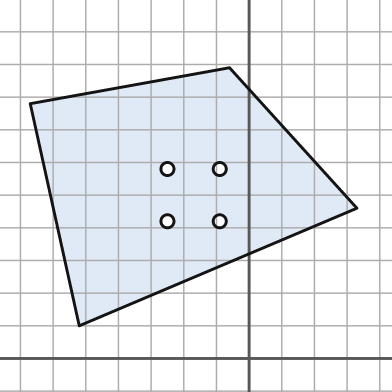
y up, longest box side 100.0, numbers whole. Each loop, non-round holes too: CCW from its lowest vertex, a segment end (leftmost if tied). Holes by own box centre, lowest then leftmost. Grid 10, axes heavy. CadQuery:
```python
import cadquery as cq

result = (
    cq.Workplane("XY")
    .moveTo(-52.0, 10.0)
    .lineTo(33.0, 46.0)
    .lineTo(-6.0, 89.0)
    .lineTo(-67.0, 78.0)
    .close()
    .moveTo(-25.0, 42.0)
    .circle(2.0)
    .moveTo(-9.0, 42.0)
    .circle(2.0)
    .moveTo(-25.0, 58.0)
    .circle(2.0)
    .moveTo(-9.0, 58.0)
    .circle(2.0)
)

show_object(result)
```